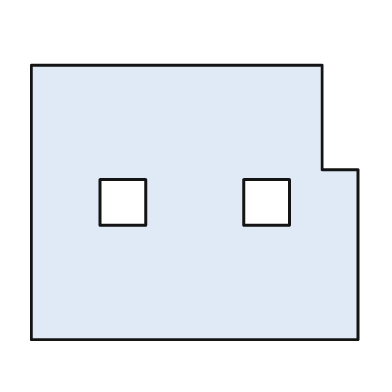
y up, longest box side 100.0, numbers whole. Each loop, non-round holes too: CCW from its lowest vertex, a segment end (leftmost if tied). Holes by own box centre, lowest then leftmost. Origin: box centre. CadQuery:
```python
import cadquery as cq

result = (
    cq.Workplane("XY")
    .moveTo(-50.0, -42.0)
    .lineTo(50.0, -42.0)
    .lineTo(50.0, 10.0)
    .lineTo(39.0, 10.0)
    .lineTo(39.0, 42.0)
    .lineTo(-50.0, 42.0)
    .close()
    .moveTo(-29.0, -7.0)
    .lineTo(-15.0, -7.0)
    .lineTo(-15.0, 7.0)
    .lineTo(-29.0, 7.0)
    .close()
    .moveTo(15.0, -7.0)
    .lineTo(29.0, -7.0)
    .lineTo(29.0, 7.0)
    .lineTo(15.0, 7.0)
    .close()
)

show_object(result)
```